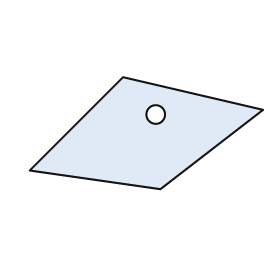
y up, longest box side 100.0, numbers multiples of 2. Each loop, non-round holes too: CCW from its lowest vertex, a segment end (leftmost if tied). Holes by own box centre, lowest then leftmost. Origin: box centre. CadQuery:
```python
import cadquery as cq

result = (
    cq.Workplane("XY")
    .moveTo(6.0, -24.0)
    .lineTo(50.0, 10.0)
    .lineTo(-10.0, 24.0)
    .lineTo(-50.0, -16.0)
    .close()
    .moveTo(4.0, 8.0)
    .circle(4.0)
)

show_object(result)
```